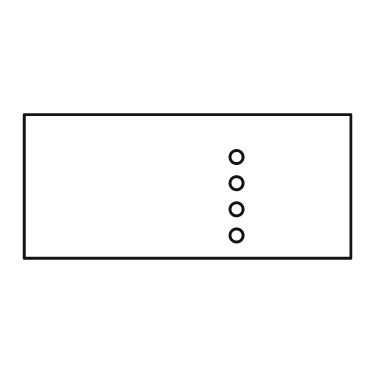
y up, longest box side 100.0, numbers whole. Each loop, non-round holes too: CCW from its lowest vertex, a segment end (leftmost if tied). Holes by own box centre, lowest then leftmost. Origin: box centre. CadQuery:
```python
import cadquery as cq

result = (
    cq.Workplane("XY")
    .moveTo(-50.0, -22.0)
    .lineTo(50.0, -22.0)
    .lineTo(50.0, 22.0)
    .lineTo(-50.0, 22.0)
    .close()
    .moveTo(15.0, -15.0)
    .circle(2.0)
    .moveTo(15.0, -7.0)
    .circle(2.0)
    .moveTo(15.0, 1.0)
    .circle(2.0)
    .moveTo(15.0, 9.0)
    .circle(2.0)
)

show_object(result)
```